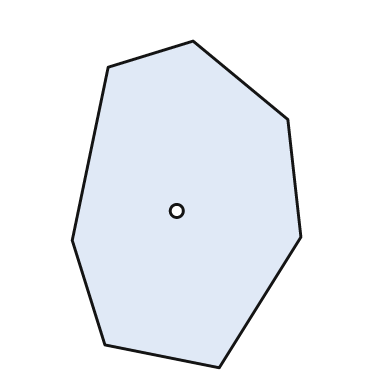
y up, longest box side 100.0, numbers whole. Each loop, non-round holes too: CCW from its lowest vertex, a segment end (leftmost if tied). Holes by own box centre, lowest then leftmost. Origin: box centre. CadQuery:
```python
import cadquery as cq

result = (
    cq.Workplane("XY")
    .moveTo(10.0, -50.0)
    .lineTo(35.0, -10.0)
    .lineTo(31.0, 26.0)
    .lineTo(2.0, 50.0)
    .lineTo(-24.0, 42.0)
    .lineTo(-35.0, -11.0)
    .lineTo(-25.0, -43.0)
    .close()
    .moveTo(-3.0, -2.0)
    .circle(2.0)
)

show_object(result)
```